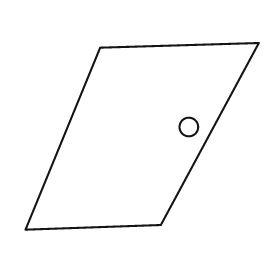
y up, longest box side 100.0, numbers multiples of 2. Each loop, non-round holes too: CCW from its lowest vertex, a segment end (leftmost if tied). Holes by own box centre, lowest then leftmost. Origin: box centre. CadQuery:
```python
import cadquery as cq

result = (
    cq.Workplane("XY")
    .moveTo(-50.0, -40.0)
    .lineTo(8.0, -38.0)
    .lineTo(50.0, 40.0)
    .lineTo(-18.0, 38.0)
    .close()
    .moveTo(20.0, 4.0)
    .circle(4.0)
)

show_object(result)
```